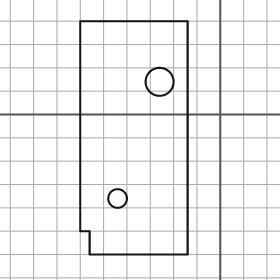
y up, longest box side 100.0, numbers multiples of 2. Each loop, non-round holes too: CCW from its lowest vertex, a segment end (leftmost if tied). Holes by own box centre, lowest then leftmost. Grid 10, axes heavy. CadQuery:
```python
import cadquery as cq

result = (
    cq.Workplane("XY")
    .moveTo(-56.0, -60.0)
    .lineTo(-14.0, -60.0)
    .lineTo(-14.0, 40.0)
    .lineTo(-60.0, 40.0)
    .lineTo(-60.0, -50.0)
    .lineTo(-56.0, -50.0)
    .close()
    .moveTo(-44.0, -36.0)
    .circle(4.0)
    .moveTo(-26.0, 14.0)
    .circle(6.0)
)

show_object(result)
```